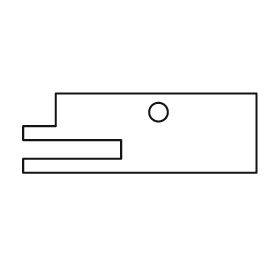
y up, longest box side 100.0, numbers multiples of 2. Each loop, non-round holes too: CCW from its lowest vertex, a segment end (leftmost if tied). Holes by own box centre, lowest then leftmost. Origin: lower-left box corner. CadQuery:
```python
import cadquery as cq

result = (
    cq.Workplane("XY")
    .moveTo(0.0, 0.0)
    .lineTo(100.0, 0.0)
    .lineTo(100.0, 34.0)
    .lineTo(14.0, 34.0)
    .lineTo(14.0, 20.0)
    .lineTo(0.0, 20.0)
    .lineTo(0.0, 14.0)
    .lineTo(42.0, 14.0)
    .lineTo(42.0, 6.0)
    .lineTo(0.0, 6.0)
    .close()
    .moveTo(58.0, 26.0)
    .circle(4.0)
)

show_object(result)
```